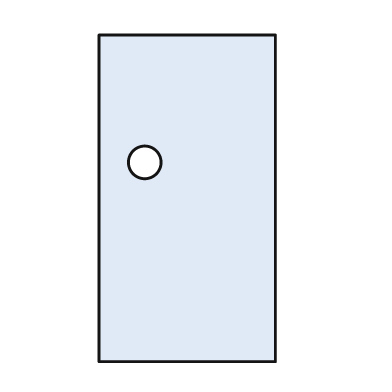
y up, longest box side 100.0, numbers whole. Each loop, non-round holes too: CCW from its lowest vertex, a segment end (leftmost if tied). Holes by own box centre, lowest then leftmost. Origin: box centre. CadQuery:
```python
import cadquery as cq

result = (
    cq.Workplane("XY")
    .moveTo(-27.0, -50.0)
    .lineTo(27.0, -50.0)
    .lineTo(27.0, 50.0)
    .lineTo(-27.0, 50.0)
    .close()
    .moveTo(-13.0, 11.0)
    .circle(5.0)
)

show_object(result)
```